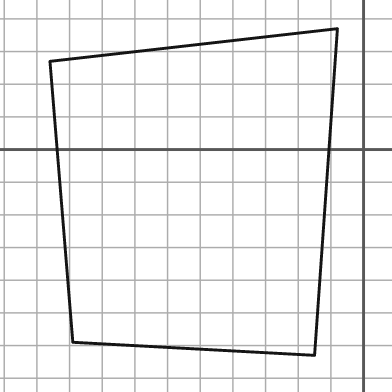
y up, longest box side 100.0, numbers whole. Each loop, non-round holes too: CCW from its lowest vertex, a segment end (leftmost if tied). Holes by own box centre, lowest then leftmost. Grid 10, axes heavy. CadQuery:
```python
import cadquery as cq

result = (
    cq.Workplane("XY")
    .moveTo(-15.0, -63.0)
    .lineTo(-8.0, 37.0)
    .lineTo(-96.0, 27.0)
    .lineTo(-89.0, -59.0)
    .close()
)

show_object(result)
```